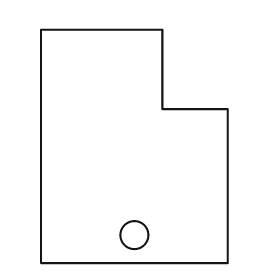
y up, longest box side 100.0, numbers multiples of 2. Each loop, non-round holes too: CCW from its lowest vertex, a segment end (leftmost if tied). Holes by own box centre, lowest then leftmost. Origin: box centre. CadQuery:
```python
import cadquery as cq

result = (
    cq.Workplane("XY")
    .moveTo(-40.0, -50.0)
    .lineTo(40.0, -50.0)
    .lineTo(40.0, 16.0)
    .lineTo(12.0, 16.0)
    .lineTo(12.0, 50.0)
    .lineTo(-40.0, 50.0)
    .close()
    .moveTo(0.0, -38.0)
    .circle(6.0)
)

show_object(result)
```